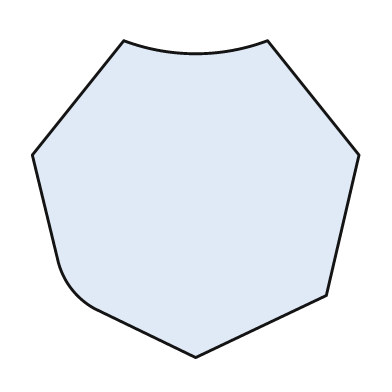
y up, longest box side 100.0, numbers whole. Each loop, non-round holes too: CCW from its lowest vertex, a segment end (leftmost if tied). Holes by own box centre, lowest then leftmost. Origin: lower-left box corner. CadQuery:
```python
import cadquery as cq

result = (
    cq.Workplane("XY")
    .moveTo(50.0, 0.0)
    .lineTo(90.0, 19.0)
    .lineTo(100.0, 62.0)
    .lineTo(72.0, 97.0)
    .threePointArc((50.0, 93.0), (28.0, 97.0))
    .lineTo(0.0, 62.0)
    .lineTo(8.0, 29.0)
    .threePointArc((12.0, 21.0), (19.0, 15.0))
    .close()
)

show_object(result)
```